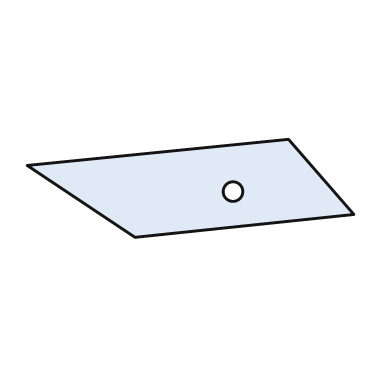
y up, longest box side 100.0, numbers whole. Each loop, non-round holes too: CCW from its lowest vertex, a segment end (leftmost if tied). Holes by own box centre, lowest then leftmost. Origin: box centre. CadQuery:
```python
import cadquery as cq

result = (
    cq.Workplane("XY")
    .moveTo(-17.0, -15.0)
    .lineTo(50.0, -8.0)
    .lineTo(30.0, 15.0)
    .lineTo(-50.0, 7.0)
    .close()
    .moveTo(13.0, -1.0)
    .circle(3.0)
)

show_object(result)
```